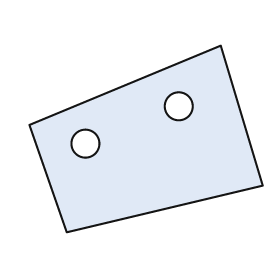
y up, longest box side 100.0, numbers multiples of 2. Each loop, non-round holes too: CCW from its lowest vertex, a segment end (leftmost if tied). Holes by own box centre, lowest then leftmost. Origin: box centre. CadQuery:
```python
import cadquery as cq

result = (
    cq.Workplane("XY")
    .moveTo(-34.0, -40.0)
    .lineTo(50.0, -20.0)
    .lineTo(32.0, 40.0)
    .lineTo(-50.0, 6.0)
    .close()
    .moveTo(-26.0, -2.0)
    .circle(6.0)
    .moveTo(14.0, 14.0)
    .circle(6.0)
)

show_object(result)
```